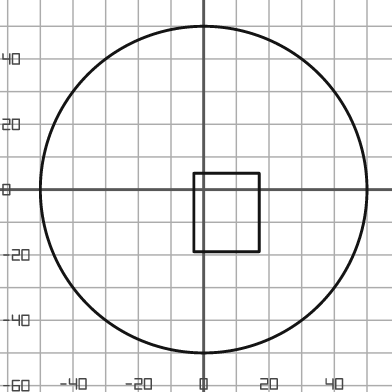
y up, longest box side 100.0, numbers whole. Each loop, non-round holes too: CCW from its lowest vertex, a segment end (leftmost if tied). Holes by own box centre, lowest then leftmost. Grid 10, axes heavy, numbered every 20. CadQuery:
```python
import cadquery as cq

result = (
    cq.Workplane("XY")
    .moveTo(0.0, 0.0)
    .circle(50.0)
    .moveTo(-3.0, -19.0)
    .lineTo(17.0, -19.0)
    .lineTo(17.0, 5.0)
    .lineTo(-3.0, 5.0)
    .close()
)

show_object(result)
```